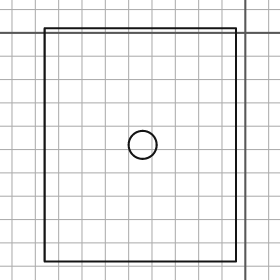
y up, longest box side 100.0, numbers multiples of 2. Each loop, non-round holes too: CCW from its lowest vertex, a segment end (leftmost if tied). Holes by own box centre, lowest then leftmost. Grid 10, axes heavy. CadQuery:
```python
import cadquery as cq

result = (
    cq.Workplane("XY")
    .moveTo(-86.0, -98.0)
    .lineTo(-4.0, -98.0)
    .lineTo(-4.0, 2.0)
    .lineTo(-86.0, 2.0)
    .close()
    .moveTo(-44.0, -48.0)
    .circle(6.0)
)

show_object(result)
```